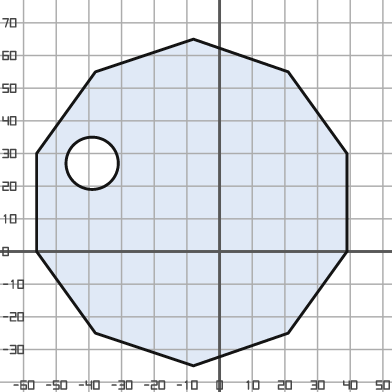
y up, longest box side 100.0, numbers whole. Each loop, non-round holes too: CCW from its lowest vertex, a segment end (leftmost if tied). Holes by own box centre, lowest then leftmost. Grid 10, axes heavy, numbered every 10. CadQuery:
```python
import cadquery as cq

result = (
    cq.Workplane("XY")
    .moveTo(-8.0, -35.0)
    .lineTo(21.0, -25.0)
    .lineTo(39.0, 0.0)
    .lineTo(39.0, 30.0)
    .lineTo(21.0, 55.0)
    .lineTo(-8.0, 65.0)
    .lineTo(-38.0, 55.0)
    .lineTo(-56.0, 30.0)
    .lineTo(-56.0, 0.0)
    .lineTo(-38.0, -25.0)
    .close()
    .moveTo(-39.0, 27.0)
    .circle(8.0)
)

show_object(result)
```